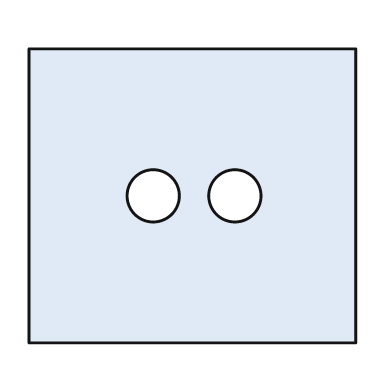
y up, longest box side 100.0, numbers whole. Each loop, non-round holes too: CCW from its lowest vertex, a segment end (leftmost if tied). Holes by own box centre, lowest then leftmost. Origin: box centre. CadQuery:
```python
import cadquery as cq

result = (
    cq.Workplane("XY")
    .moveTo(-50.0, -45.0)
    .lineTo(50.0, -45.0)
    .lineTo(50.0, 45.0)
    .lineTo(-50.0, 45.0)
    .close()
    .moveTo(-12.0, 0.0)
    .circle(8.0)
    .moveTo(13.0, 0.0)
    .circle(8.0)
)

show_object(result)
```